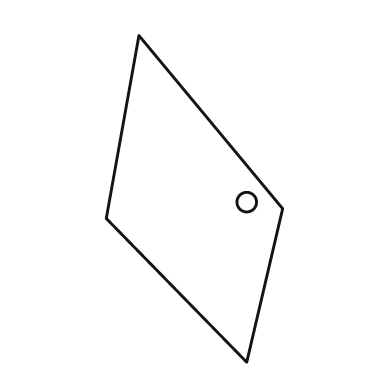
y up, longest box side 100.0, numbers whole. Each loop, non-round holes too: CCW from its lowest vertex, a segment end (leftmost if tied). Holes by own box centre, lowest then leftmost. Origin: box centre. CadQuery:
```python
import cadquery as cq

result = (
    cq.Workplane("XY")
    .moveTo(16.0, -50.0)
    .lineTo(27.0, -3.0)
    .lineTo(-17.0, 50.0)
    .lineTo(-27.0, -6.0)
    .close()
    .moveTo(16.0, -1.0)
    .circle(3.0)
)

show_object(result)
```